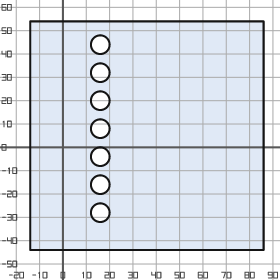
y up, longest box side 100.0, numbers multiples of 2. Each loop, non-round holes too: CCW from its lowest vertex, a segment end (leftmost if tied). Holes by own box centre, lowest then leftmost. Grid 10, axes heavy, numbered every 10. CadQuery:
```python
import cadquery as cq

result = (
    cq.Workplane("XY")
    .moveTo(-14.0, -44.0)
    .lineTo(86.0, -44.0)
    .lineTo(86.0, 54.0)
    .lineTo(-14.0, 54.0)
    .close()
    .moveTo(16.0, -28.0)
    .circle(4.0)
    .moveTo(16.0, -16.0)
    .circle(4.0)
    .moveTo(16.0, -4.0)
    .circle(4.0)
    .moveTo(16.0, 8.0)
    .circle(4.0)
    .moveTo(16.0, 20.0)
    .circle(4.0)
    .moveTo(16.0, 32.0)
    .circle(4.0)
    .moveTo(16.0, 44.0)
    .circle(4.0)
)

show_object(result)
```